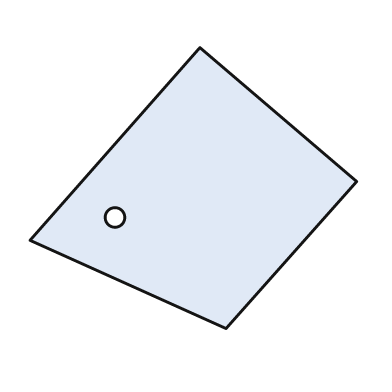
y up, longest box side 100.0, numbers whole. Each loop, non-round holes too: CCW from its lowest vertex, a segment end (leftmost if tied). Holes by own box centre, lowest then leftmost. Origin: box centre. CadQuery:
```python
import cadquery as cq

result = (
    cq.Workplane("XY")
    .moveTo(10.0, -43.0)
    .lineTo(50.0, 2.0)
    .lineTo(2.0, 43.0)
    .lineTo(-50.0, -16.0)
    .close()
    .moveTo(-24.0, -9.0)
    .circle(3.0)
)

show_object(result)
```